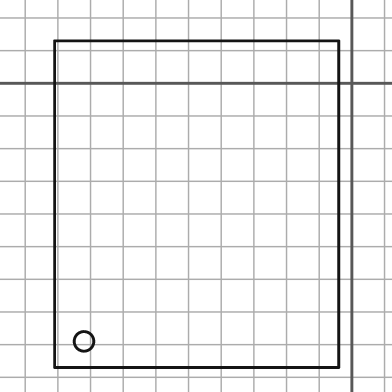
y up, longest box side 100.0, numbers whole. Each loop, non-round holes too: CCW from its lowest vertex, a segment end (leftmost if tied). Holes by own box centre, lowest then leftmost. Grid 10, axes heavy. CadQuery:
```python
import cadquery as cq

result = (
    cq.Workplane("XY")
    .moveTo(-91.0, -87.0)
    .lineTo(-4.0, -87.0)
    .lineTo(-4.0, 13.0)
    .lineTo(-91.0, 13.0)
    .close()
    .moveTo(-82.0, -79.0)
    .circle(3.0)
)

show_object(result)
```